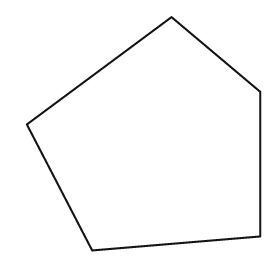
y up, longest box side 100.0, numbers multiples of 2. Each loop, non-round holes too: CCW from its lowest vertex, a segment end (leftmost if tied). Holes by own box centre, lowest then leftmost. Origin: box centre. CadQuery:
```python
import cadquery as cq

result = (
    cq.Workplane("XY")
    .moveTo(-22.0, -50.0)
    .lineTo(50.0, -44.0)
    .lineTo(50.0, 18.0)
    .lineTo(12.0, 50.0)
    .lineTo(-50.0, 4.0)
    .close()
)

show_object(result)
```